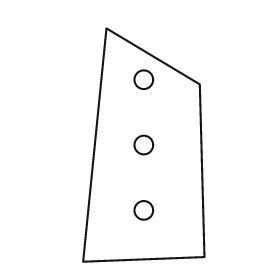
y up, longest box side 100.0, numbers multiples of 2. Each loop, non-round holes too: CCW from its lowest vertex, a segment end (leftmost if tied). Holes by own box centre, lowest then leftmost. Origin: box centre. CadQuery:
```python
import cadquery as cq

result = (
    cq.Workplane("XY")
    .moveTo(-26.0, -50.0)
    .lineTo(26.0, -48.0)
    .lineTo(24.0, 26.0)
    .lineTo(-16.0, 50.0)
    .close()
    .moveTo(0.0, -28.0)
    .circle(4.0)
    .moveTo(0.0, 0.0)
    .circle(4.0)
    .moveTo(0.0, 28.0)
    .circle(4.0)
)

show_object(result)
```